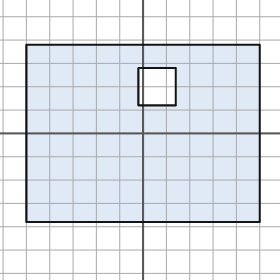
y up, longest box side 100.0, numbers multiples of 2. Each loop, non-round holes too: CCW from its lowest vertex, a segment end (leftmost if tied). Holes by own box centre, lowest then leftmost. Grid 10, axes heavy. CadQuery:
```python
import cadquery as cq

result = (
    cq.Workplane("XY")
    .moveTo(-50.0, -38.0)
    .lineTo(50.0, -38.0)
    .lineTo(50.0, 38.0)
    .lineTo(-50.0, 38.0)
    .close()
    .moveTo(-2.0, 12.0)
    .lineTo(14.0, 12.0)
    .lineTo(14.0, 28.0)
    .lineTo(-2.0, 28.0)
    .close()
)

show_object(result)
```